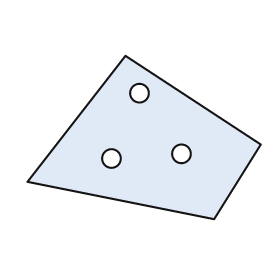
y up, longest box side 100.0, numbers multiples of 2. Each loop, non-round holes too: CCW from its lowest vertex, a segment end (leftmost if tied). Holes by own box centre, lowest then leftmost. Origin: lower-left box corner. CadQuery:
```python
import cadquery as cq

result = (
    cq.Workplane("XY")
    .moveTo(80.0, 0.0)
    .lineTo(100.0, 32.0)
    .lineTo(42.0, 70.0)
    .lineTo(0.0, 16.0)
    .close()
    .moveTo(36.0, 26.0)
    .circle(4.0)
    .moveTo(66.0, 28.0)
    .circle(4.0)
    .moveTo(48.0, 54.0)
    .circle(4.0)
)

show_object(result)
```